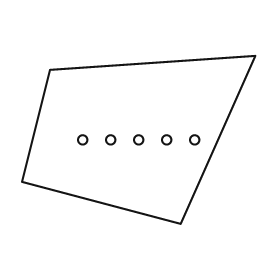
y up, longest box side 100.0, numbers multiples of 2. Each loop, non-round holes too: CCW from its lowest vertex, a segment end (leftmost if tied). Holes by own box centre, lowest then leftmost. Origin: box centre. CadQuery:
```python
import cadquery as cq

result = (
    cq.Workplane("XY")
    .moveTo(18.0, -36.0)
    .lineTo(50.0, 36.0)
    .lineTo(-38.0, 30.0)
    .lineTo(-50.0, -18.0)
    .close()
    .moveTo(-24.0, 0.0)
    .circle(2.0)
    .moveTo(-12.0, 0.0)
    .circle(2.0)
    .moveTo(0.0, 0.0)
    .circle(2.0)
    .moveTo(12.0, 0.0)
    .circle(2.0)
    .moveTo(24.0, 0.0)
    .circle(2.0)
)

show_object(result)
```